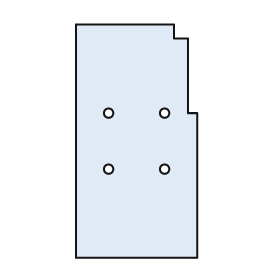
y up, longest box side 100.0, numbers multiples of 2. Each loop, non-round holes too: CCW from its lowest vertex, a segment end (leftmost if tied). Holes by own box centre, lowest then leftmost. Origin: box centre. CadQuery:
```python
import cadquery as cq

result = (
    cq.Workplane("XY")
    .moveTo(-26.0, -50.0)
    .lineTo(26.0, -50.0)
    .lineTo(26.0, 12.0)
    .lineTo(22.0, 12.0)
    .lineTo(22.0, 44.0)
    .lineTo(16.0, 44.0)
    .lineTo(16.0, 50.0)
    .lineTo(-26.0, 50.0)
    .close()
    .moveTo(-12.0, -12.0)
    .circle(2.0)
    .moveTo(12.0, -12.0)
    .circle(2.0)
    .moveTo(-12.0, 12.0)
    .circle(2.0)
    .moveTo(12.0, 12.0)
    .circle(2.0)
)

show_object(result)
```